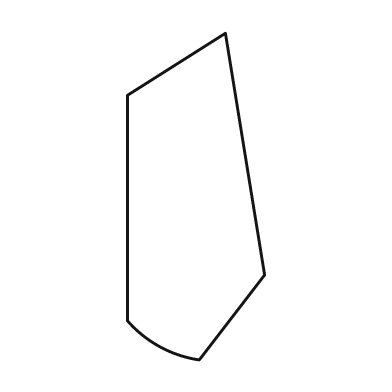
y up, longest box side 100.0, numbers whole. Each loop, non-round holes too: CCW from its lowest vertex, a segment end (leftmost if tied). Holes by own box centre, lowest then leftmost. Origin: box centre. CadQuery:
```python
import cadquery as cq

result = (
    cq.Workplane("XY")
    .moveTo(1.0, -50.0)
    .lineTo(21.0, -24.0)
    .lineTo(9.0, 50.0)
    .lineTo(-21.0, 31.0)
    .lineTo(-21.0, -38.0)
    .threePointArc((-11.0, -46.0), (1.0, -50.0))
    .close()
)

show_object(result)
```